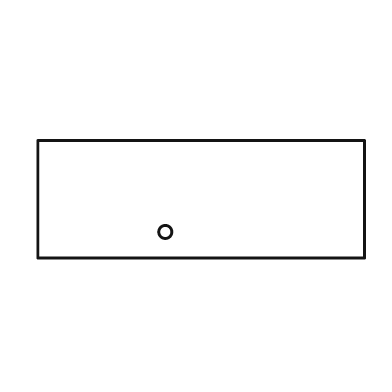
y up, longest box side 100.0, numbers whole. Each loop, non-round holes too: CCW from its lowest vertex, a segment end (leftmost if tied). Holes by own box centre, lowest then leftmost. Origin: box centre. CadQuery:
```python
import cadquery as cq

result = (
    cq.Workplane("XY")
    .moveTo(-50.0, -18.0)
    .lineTo(50.0, -18.0)
    .lineTo(50.0, 18.0)
    .lineTo(-50.0, 18.0)
    .close()
    .moveTo(-11.0, -10.0)
    .circle(2.0)
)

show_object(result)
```